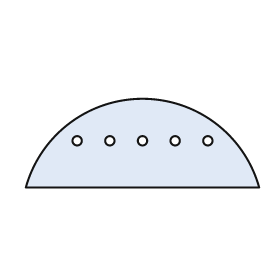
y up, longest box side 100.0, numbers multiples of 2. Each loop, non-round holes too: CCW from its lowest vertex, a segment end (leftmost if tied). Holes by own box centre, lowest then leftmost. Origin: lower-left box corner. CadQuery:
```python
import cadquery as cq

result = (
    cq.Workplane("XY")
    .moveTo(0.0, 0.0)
    .lineTo(100.0, 0.0)
    .threePointArc((50.0, 38.0), (0.0, 0.0))
    .close()
    .moveTo(22.0, 20.0)
    .circle(2.0)
    .moveTo(36.0, 20.0)
    .circle(2.0)
    .moveTo(50.0, 20.0)
    .circle(2.0)
    .moveTo(64.0, 20.0)
    .circle(2.0)
    .moveTo(78.0, 20.0)
    .circle(2.0)
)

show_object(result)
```